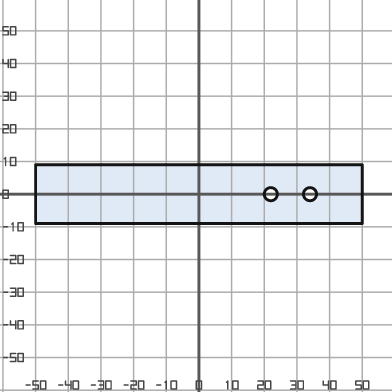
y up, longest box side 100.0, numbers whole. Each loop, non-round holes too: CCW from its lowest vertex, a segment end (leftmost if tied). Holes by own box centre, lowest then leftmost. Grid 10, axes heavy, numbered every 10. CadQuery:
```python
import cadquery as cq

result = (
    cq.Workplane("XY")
    .moveTo(-50.0, -9.0)
    .lineTo(50.0, -9.0)
    .lineTo(50.0, 9.0)
    .lineTo(-50.0, 9.0)
    .close()
    .moveTo(22.0, 0.0)
    .circle(2.0)
    .moveTo(34.0, 0.0)
    .circle(2.0)
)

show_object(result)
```